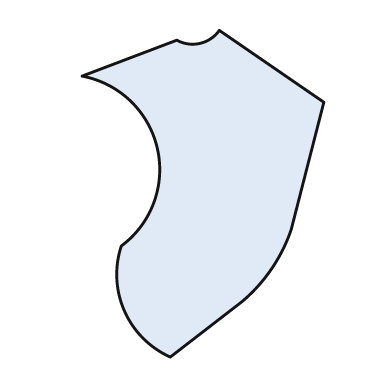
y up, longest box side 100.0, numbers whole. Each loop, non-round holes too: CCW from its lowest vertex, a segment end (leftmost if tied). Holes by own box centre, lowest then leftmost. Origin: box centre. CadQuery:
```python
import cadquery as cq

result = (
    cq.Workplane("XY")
    .moveTo(-10.0, -50.0)
    .lineTo(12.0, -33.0)
    .threePointArc((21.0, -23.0), (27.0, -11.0))
    .lineTo(37.0, 28.0)
    .lineTo(5.0, 50.0)
    .threePointArc((-1.0, 46.0), (-8.0, 47.0))
    .lineTo(-37.0, 36.0)
    .threePointArc((-14.0, 14.0), (-25.0, -16.0))
    .threePointArc((-24.0, -36.0), (-10.0, -50.0))
    .close()
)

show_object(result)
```